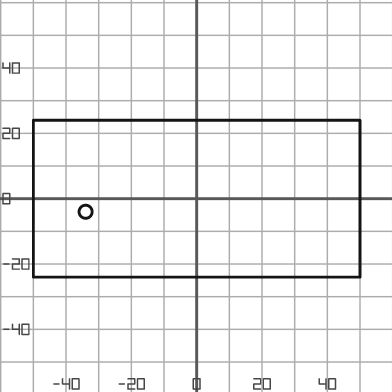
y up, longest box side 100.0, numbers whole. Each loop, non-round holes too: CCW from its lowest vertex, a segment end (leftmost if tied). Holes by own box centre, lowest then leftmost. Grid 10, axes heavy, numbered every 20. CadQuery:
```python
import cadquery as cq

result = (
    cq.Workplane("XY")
    .moveTo(-50.0, -24.0)
    .lineTo(50.0, -24.0)
    .lineTo(50.0, 24.0)
    .lineTo(-50.0, 24.0)
    .close()
    .moveTo(-34.0, -4.0)
    .circle(2.0)
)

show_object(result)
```